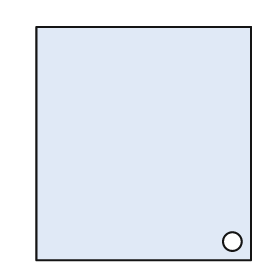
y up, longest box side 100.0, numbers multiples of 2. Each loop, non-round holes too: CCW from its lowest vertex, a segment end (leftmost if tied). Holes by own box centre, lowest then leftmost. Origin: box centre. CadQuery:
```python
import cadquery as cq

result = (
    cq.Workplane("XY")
    .moveTo(-46.0, -50.0)
    .lineTo(46.0, -50.0)
    .lineTo(46.0, 50.0)
    .lineTo(-46.0, 50.0)
    .close()
    .moveTo(38.0, -42.0)
    .circle(4.0)
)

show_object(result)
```